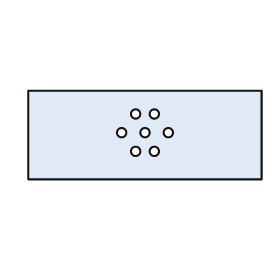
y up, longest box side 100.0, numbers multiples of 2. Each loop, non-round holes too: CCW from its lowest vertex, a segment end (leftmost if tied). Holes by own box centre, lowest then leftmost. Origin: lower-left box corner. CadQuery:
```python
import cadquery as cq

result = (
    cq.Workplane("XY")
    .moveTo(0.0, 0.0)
    .lineTo(100.0, 0.0)
    .lineTo(100.0, 38.0)
    .lineTo(0.0, 38.0)
    .close()
    .moveTo(46.0, 12.0)
    .circle(2.0)
    .moveTo(54.0, 12.0)
    .circle(2.0)
    .moveTo(40.0, 20.0)
    .circle(2.0)
    .moveTo(50.0, 20.0)
    .circle(2.0)
    .moveTo(60.0, 20.0)
    .circle(2.0)
    .moveTo(46.0, 28.0)
    .circle(2.0)
    .moveTo(54.0, 28.0)
    .circle(2.0)
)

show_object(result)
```